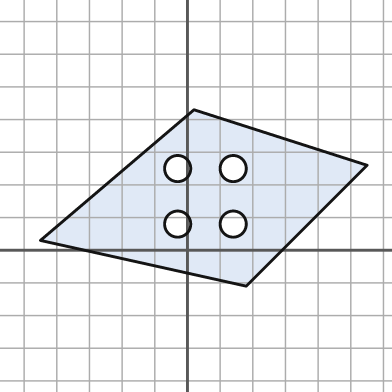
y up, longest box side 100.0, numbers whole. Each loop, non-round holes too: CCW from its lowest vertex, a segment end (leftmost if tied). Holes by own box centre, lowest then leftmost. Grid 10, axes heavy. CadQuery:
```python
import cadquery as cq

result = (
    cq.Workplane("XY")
    .moveTo(18.0, -11.0)
    .lineTo(55.0, 26.0)
    .lineTo(2.0, 43.0)
    .lineTo(-45.0, 3.0)
    .close()
    .moveTo(-3.0, 8.0)
    .circle(4.0)
    .moveTo(14.0, 8.0)
    .circle(4.0)
    .moveTo(-3.0, 25.0)
    .circle(4.0)
    .moveTo(14.0, 25.0)
    .circle(4.0)
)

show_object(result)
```